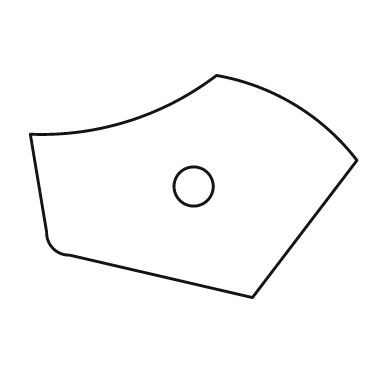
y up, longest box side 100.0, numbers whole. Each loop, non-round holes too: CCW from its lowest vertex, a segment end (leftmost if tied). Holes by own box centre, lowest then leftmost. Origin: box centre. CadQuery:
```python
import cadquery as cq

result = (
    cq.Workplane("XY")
    .moveTo(18.0, -34.0)
    .lineTo(50.0, 8.0)
    .threePointArc((31.0, 25.0), (7.0, 34.0))
    .threePointArc((-20.0, 20.0), (-50.0, 16.0))
    .lineTo(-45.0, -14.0)
    .threePointArc((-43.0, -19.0), (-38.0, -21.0))
    .close()
    .moveTo(0.0, 0.0)
    .circle(6.0)
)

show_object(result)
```